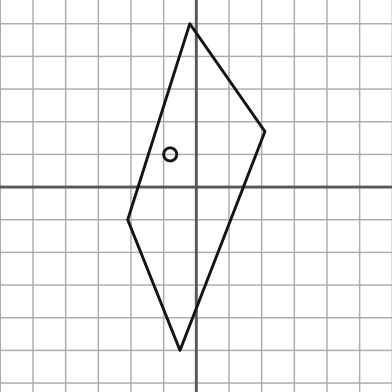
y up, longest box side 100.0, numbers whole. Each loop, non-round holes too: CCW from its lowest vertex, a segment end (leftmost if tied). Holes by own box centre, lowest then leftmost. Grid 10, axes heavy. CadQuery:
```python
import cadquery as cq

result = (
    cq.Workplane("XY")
    .moveTo(-5.0, -50.0)
    .lineTo(21.0, 17.0)
    .lineTo(-2.0, 50.0)
    .lineTo(-21.0, -10.0)
    .close()
    .moveTo(-8.0, 10.0)
    .circle(2.0)
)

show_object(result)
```